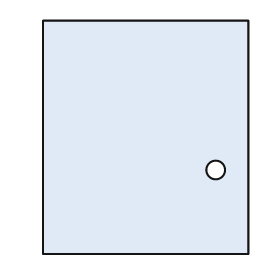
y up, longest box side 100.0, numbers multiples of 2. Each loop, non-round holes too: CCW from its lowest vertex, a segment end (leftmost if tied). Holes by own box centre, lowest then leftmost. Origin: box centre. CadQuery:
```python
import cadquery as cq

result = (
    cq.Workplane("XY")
    .moveTo(-44.0, -50.0)
    .lineTo(44.0, -50.0)
    .lineTo(44.0, 50.0)
    .lineTo(-44.0, 50.0)
    .close()
    .moveTo(30.0, -14.0)
    .circle(4.0)
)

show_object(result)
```